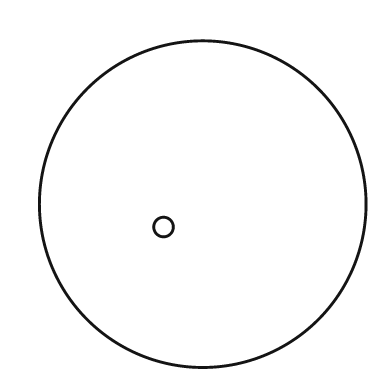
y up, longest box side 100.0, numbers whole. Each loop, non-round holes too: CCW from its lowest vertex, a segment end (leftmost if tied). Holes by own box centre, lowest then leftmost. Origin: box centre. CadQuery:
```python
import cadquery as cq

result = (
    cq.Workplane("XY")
    .moveTo(0.0, 0.0)
    .circle(50.0)
    .moveTo(-12.0, -7.0)
    .circle(3.0)
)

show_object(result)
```